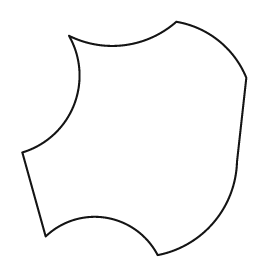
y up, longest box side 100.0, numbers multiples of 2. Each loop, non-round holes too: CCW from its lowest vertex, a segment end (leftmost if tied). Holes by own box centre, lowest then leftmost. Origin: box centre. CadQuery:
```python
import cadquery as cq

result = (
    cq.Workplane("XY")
    .moveTo(10.0, -50.0)
    .threePointArc((34.0, -36.0), (44.0, -10.0))
    .lineTo(48.0, 26.0)
    .threePointArc((36.0, 42.0), (18.0, 50.0))
    .threePointArc((-4.0, 40.0), (-28.0, 44.0))
    .threePointArc((-26.0, 14.0), (-48.0, -6.0))
    .lineTo(-38.0, -42.0)
    .threePointArc((-12.0, -34.0), (10.0, -50.0))
    .close()
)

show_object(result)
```